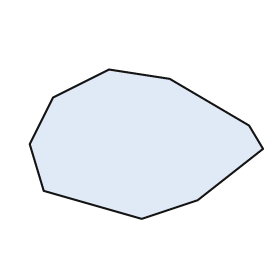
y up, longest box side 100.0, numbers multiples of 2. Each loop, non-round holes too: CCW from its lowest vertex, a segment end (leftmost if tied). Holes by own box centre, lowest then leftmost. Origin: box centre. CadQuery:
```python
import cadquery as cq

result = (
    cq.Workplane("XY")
    .moveTo(-2.0, -32.0)
    .lineTo(22.0, -24.0)
    .lineTo(50.0, -2.0)
    .lineTo(44.0, 8.0)
    .lineTo(10.0, 28.0)
    .lineTo(-16.0, 32.0)
    .lineTo(-40.0, 20.0)
    .lineTo(-50.0, 0.0)
    .lineTo(-44.0, -20.0)
    .close()
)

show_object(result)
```